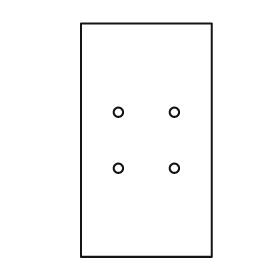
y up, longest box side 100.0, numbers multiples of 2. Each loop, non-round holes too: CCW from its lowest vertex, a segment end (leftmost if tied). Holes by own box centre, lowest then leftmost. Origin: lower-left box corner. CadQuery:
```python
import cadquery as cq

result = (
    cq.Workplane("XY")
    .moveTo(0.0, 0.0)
    .lineTo(56.0, 0.0)
    .lineTo(56.0, 100.0)
    .lineTo(0.0, 100.0)
    .close()
    .moveTo(16.0, 38.0)
    .circle(2.0)
    .moveTo(40.0, 38.0)
    .circle(2.0)
    .moveTo(16.0, 62.0)
    .circle(2.0)
    .moveTo(40.0, 62.0)
    .circle(2.0)
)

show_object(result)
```